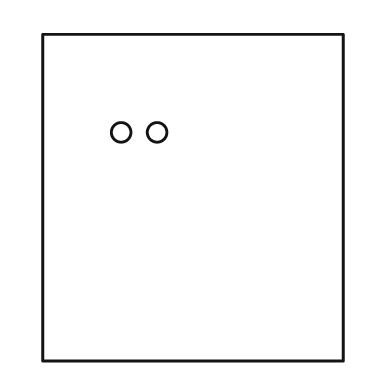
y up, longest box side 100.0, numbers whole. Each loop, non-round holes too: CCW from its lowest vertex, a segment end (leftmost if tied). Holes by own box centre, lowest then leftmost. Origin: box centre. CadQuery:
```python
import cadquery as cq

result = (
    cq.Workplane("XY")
    .moveTo(-46.0, -50.0)
    .lineTo(46.0, -50.0)
    .lineTo(46.0, 50.0)
    .lineTo(-46.0, 50.0)
    .close()
    .moveTo(-22.0, 20.0)
    .circle(3.0)
    .moveTo(-11.0, 20.0)
    .circle(3.0)
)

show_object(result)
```